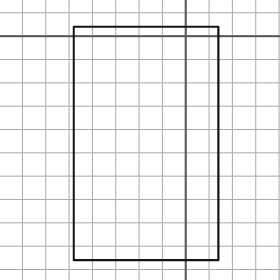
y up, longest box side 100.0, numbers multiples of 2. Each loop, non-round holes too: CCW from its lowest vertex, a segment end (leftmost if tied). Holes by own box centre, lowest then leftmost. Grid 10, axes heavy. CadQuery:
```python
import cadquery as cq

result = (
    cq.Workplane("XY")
    .moveTo(-48.0, -96.0)
    .lineTo(14.0, -96.0)
    .lineTo(14.0, 4.0)
    .lineTo(-48.0, 4.0)
    .close()
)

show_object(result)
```